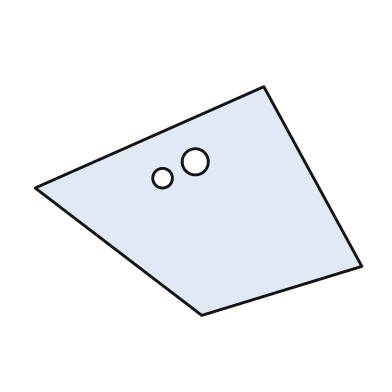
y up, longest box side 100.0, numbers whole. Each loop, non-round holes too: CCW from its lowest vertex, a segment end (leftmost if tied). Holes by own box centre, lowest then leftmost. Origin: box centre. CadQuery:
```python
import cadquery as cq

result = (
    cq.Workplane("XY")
    .moveTo(1.0, -35.0)
    .lineTo(50.0, -20.0)
    .lineTo(20.0, 35.0)
    .lineTo(-50.0, 4.0)
    .close()
    .moveTo(-11.0, 7.0)
    .circle(3.0)
    .moveTo(-1.0, 12.0)
    .circle(4.0)
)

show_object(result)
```